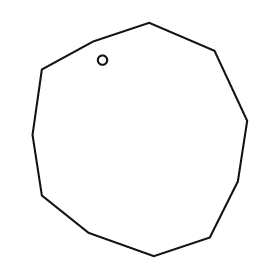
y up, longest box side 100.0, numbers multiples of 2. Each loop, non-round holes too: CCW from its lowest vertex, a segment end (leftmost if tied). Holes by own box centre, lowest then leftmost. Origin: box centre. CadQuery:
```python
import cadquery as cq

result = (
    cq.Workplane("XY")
    .moveTo(6.0, -50.0)
    .lineTo(30.0, -42.0)
    .lineTo(42.0, -18.0)
    .lineTo(46.0, 8.0)
    .lineTo(32.0, 38.0)
    .lineTo(4.0, 50.0)
    .lineTo(-20.0, 42.0)
    .lineTo(-42.0, 30.0)
    .lineTo(-46.0, 2.0)
    .lineTo(-42.0, -24.0)
    .lineTo(-22.0, -40.0)
    .close()
    .moveTo(-16.0, 34.0)
    .circle(2.0)
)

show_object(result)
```